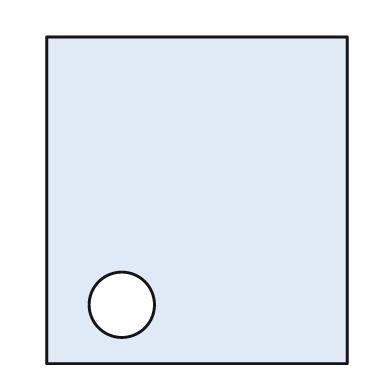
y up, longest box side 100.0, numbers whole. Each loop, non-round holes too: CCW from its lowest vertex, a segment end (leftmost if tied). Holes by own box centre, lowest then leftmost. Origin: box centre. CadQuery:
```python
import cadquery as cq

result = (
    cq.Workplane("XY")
    .moveTo(-46.0, -50.0)
    .lineTo(46.0, -50.0)
    .lineTo(46.0, 50.0)
    .lineTo(-46.0, 50.0)
    .close()
    .moveTo(-23.0, -32.0)
    .circle(10.0)
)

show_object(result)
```